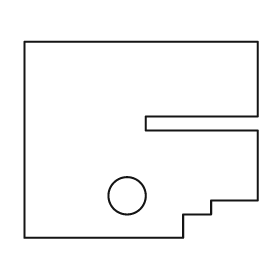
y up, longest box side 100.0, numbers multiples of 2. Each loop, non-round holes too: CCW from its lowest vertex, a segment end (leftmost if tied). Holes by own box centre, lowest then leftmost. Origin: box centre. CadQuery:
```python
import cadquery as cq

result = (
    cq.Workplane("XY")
    .moveTo(-50.0, -42.0)
    .lineTo(18.0, -42.0)
    .lineTo(18.0, -32.0)
    .lineTo(30.0, -32.0)
    .lineTo(30.0, -26.0)
    .lineTo(50.0, -26.0)
    .lineTo(50.0, 4.0)
    .lineTo(2.0, 4.0)
    .lineTo(2.0, 10.0)
    .lineTo(50.0, 10.0)
    .lineTo(50.0, 42.0)
    .lineTo(-50.0, 42.0)
    .close()
    .moveTo(-6.0, -24.0)
    .circle(8.0)
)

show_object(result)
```